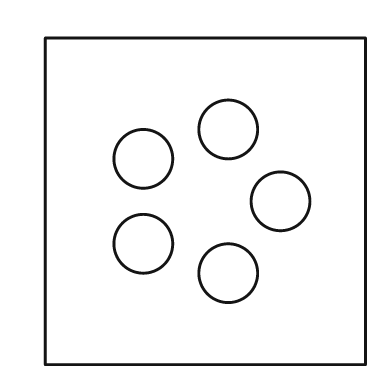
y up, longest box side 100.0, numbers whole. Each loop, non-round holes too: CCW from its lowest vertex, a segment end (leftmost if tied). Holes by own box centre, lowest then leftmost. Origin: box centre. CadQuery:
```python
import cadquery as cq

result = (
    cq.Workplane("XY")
    .moveTo(-49.0, -50.0)
    .lineTo(49.0, -50.0)
    .lineTo(49.0, 50.0)
    .lineTo(-49.0, 50.0)
    .close()
    .moveTo(7.0, -22.0)
    .circle(9.0)
    .moveTo(-19.0, -13.0)
    .circle(9.0)
    .moveTo(23.0, 0.0)
    .circle(9.0)
    .moveTo(-19.0, 13.0)
    .circle(9.0)
    .moveTo(7.0, 22.0)
    .circle(9.0)
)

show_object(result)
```